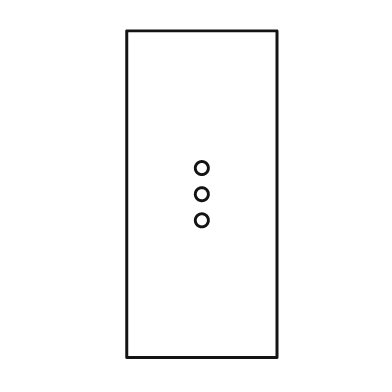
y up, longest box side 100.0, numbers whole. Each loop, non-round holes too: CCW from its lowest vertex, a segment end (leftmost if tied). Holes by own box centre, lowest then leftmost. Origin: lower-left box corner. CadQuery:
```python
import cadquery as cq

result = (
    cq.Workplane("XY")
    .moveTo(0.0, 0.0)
    .lineTo(46.0, 0.0)
    .lineTo(46.0, 100.0)
    .lineTo(0.0, 100.0)
    .close()
    .moveTo(23.0, 42.0)
    .circle(2.0)
    .moveTo(23.0, 50.0)
    .circle(2.0)
    .moveTo(23.0, 58.0)
    .circle(2.0)
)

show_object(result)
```